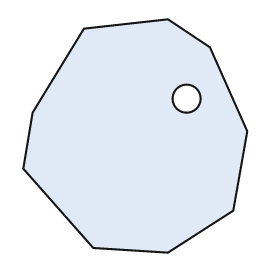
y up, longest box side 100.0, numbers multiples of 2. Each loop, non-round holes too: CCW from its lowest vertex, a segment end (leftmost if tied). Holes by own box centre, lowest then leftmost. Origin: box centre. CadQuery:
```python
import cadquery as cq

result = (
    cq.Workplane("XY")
    .moveTo(14.0, -50.0)
    .lineTo(42.0, -32.0)
    .lineTo(48.0, 2.0)
    .lineTo(32.0, 38.0)
    .lineTo(14.0, 50.0)
    .lineTo(-22.0, 46.0)
    .lineTo(-44.0, 10.0)
    .lineTo(-48.0, -14.0)
    .lineTo(-18.0, -48.0)
    .close()
    .moveTo(22.0, 16.0)
    .circle(6.0)
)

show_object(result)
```